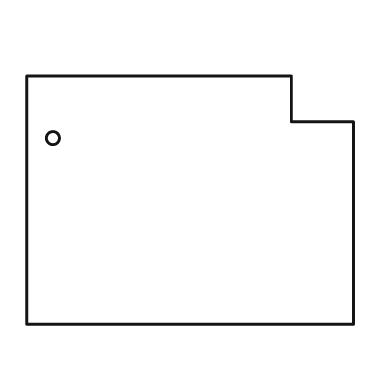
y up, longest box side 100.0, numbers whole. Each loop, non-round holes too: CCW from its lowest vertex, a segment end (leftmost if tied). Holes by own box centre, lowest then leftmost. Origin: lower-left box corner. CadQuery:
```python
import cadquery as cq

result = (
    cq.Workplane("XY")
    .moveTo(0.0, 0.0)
    .lineTo(100.0, 0.0)
    .lineTo(100.0, 62.0)
    .lineTo(81.0, 62.0)
    .lineTo(81.0, 76.0)
    .lineTo(0.0, 76.0)
    .close()
    .moveTo(8.0, 57.0)
    .circle(2.0)
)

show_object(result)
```